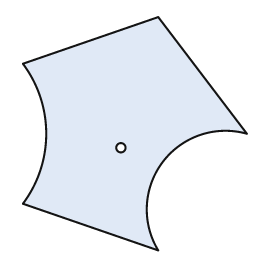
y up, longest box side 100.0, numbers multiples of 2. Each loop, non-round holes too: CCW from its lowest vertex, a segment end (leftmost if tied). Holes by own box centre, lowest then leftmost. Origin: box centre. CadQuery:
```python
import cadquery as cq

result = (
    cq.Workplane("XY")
    .moveTo(10.0, -50.0)
    .threePointArc((12.0, -12.0), (48.0, 0.0))
    .lineTo(10.0, 50.0)
    .lineTo(-48.0, 30.0)
    .threePointArc((-38.0, 0.0), (-48.0, -30.0))
    .close()
    .moveTo(-6.0, -6.0)
    .circle(2.0)
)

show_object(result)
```